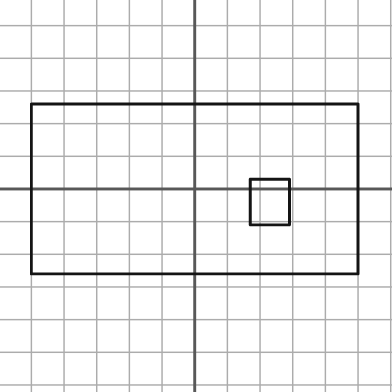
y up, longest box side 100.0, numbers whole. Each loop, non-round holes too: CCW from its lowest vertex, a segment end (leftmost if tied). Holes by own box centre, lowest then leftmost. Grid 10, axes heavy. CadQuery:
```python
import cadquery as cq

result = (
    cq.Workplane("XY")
    .moveTo(-50.0, -26.0)
    .lineTo(50.0, -26.0)
    .lineTo(50.0, 26.0)
    .lineTo(-50.0, 26.0)
    .close()
    .moveTo(17.0, -11.0)
    .lineTo(29.0, -11.0)
    .lineTo(29.0, 3.0)
    .lineTo(17.0, 3.0)
    .close()
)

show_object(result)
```